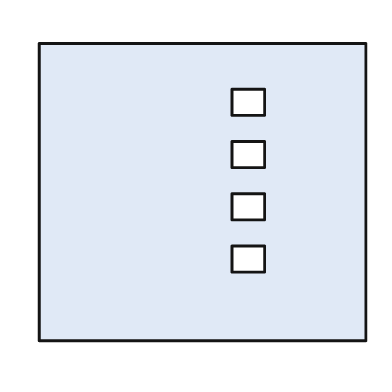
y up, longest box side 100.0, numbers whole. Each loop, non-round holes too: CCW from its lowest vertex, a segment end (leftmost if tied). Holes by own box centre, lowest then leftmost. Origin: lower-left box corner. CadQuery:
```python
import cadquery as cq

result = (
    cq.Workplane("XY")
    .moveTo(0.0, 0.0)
    .lineTo(100.0, 0.0)
    .lineTo(100.0, 91.0)
    .lineTo(0.0, 91.0)
    .close()
    .moveTo(59.0, 21.0)
    .lineTo(69.0, 21.0)
    .lineTo(69.0, 29.0)
    .lineTo(59.0, 29.0)
    .close()
    .moveTo(59.0, 37.0)
    .lineTo(69.0, 37.0)
    .lineTo(69.0, 45.0)
    .lineTo(59.0, 45.0)
    .close()
    .moveTo(59.0, 53.0)
    .lineTo(69.0, 53.0)
    .lineTo(69.0, 61.0)
    .lineTo(59.0, 61.0)
    .close()
    .moveTo(59.0, 69.0)
    .lineTo(69.0, 69.0)
    .lineTo(69.0, 77.0)
    .lineTo(59.0, 77.0)
    .close()
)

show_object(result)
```